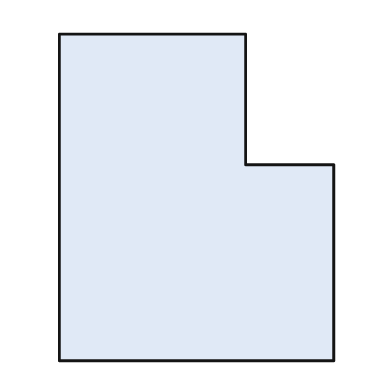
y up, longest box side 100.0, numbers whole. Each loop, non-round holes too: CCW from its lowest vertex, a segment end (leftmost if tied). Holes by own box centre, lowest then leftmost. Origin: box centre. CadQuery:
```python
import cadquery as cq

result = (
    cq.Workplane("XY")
    .moveTo(-42.0, -50.0)
    .lineTo(42.0, -50.0)
    .lineTo(42.0, 10.0)
    .lineTo(15.0, 10.0)
    .lineTo(15.0, 50.0)
    .lineTo(-42.0, 50.0)
    .close()
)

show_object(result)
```